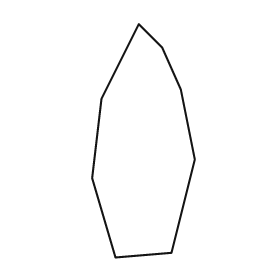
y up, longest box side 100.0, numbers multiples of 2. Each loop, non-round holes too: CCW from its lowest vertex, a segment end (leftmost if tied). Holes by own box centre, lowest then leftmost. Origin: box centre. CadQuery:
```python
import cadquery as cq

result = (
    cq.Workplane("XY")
    .moveTo(-12.0, -50.0)
    .lineTo(12.0, -48.0)
    .lineTo(22.0, -8.0)
    .lineTo(16.0, 22.0)
    .lineTo(8.0, 40.0)
    .lineTo(-2.0, 50.0)
    .lineTo(-18.0, 18.0)
    .lineTo(-22.0, -16.0)
    .close()
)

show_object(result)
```